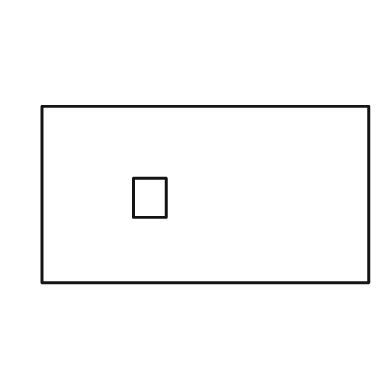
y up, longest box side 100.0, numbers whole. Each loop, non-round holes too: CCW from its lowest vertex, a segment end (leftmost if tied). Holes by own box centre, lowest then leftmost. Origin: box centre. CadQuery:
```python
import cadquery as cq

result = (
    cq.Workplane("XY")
    .moveTo(-50.0, -27.0)
    .lineTo(50.0, -27.0)
    .lineTo(50.0, 27.0)
    .lineTo(-50.0, 27.0)
    .close()
    .moveTo(-22.0, -7.0)
    .lineTo(-12.0, -7.0)
    .lineTo(-12.0, 5.0)
    .lineTo(-22.0, 5.0)
    .close()
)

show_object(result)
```